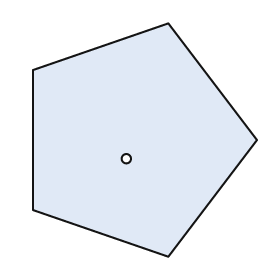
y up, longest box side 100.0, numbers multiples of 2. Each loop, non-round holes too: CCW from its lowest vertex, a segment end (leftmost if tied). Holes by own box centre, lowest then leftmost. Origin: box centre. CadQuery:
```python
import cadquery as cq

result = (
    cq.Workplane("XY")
    .moveTo(10.0, -50.0)
    .lineTo(48.0, 0.0)
    .lineTo(10.0, 50.0)
    .lineTo(-48.0, 30.0)
    .lineTo(-48.0, -30.0)
    .close()
    .moveTo(-8.0, -8.0)
    .circle(2.0)
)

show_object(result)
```